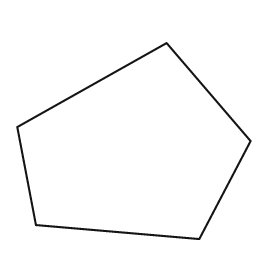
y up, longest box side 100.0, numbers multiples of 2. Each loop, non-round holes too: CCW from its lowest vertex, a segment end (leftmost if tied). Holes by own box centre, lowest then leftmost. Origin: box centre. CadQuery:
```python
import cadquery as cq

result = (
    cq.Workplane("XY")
    .moveTo(28.0, -42.0)
    .lineTo(50.0, 0.0)
    .lineTo(14.0, 42.0)
    .lineTo(-50.0, 6.0)
    .lineTo(-42.0, -36.0)
    .close()
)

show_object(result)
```